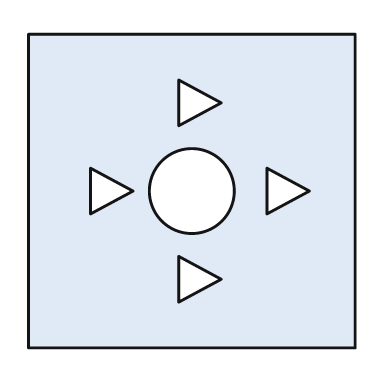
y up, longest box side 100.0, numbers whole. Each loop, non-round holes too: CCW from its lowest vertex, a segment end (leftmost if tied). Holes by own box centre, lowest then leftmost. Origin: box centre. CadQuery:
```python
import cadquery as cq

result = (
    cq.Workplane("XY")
    .moveTo(-50.0, -48.0)
    .lineTo(50.0, -48.0)
    .lineTo(50.0, 48.0)
    .lineTo(-50.0, 48.0)
    .close()
    .moveTo(-4.0, -34.0)
    .lineTo(9.0, -27.0)
    .lineTo(-4.0, -20.0)
    .close()
    .moveTo(-31.0, -7.0)
    .lineTo(-18.0, 0.0)
    .lineTo(-31.0, 7.0)
    .close()
    .moveTo(0.0, 0.0)
    .circle(13.0)
    .moveTo(23.0, -7.0)
    .lineTo(36.0, 0.0)
    .lineTo(23.0, 7.0)
    .close()
    .moveTo(-4.0, 20.0)
    .lineTo(9.0, 27.0)
    .lineTo(-4.0, 34.0)
    .close()
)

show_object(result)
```